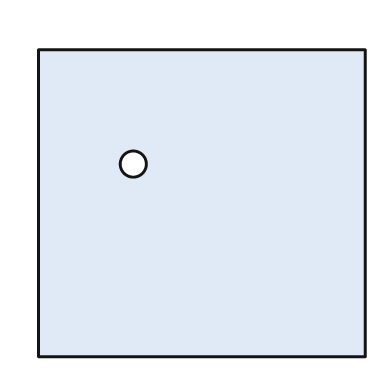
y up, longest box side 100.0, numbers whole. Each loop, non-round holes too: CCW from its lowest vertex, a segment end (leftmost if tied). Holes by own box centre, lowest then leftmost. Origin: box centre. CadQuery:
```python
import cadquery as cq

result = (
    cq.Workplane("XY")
    .moveTo(-50.0, -47.0)
    .lineTo(50.0, -47.0)
    .lineTo(50.0, 47.0)
    .lineTo(-50.0, 47.0)
    .close()
    .moveTo(-21.0, 12.0)
    .circle(4.0)
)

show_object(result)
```